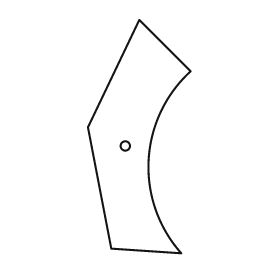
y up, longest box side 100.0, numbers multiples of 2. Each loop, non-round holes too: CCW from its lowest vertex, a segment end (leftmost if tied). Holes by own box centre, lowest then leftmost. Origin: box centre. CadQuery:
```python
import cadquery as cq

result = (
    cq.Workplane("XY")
    .moveTo(18.0, -50.0)
    .threePointArc((4.0, -10.0), (22.0, 28.0))
    .lineTo(0.0, 50.0)
    .lineTo(-22.0, 4.0)
    .lineTo(-12.0, -48.0)
    .close()
    .moveTo(-6.0, -4.0)
    .circle(2.0)
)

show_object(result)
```